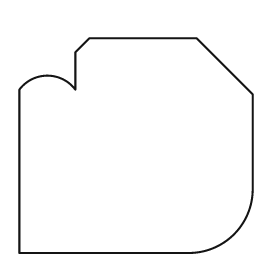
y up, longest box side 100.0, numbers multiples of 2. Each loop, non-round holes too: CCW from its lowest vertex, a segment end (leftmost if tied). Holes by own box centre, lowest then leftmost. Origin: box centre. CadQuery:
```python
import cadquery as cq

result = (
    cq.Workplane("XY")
    .moveTo(-50.0, -46.0)
    .lineTo(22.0, -46.0)
    .threePointArc((42.0, -38.0), (50.0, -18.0))
    .lineTo(50.0, 22.0)
    .lineTo(26.0, 46.0)
    .lineTo(-20.0, 46.0)
    .lineTo(-26.0, 40.0)
    .lineTo(-26.0, 24.0)
    .threePointArc((-38.0, 30.0), (-50.0, 24.0))
    .close()
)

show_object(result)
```